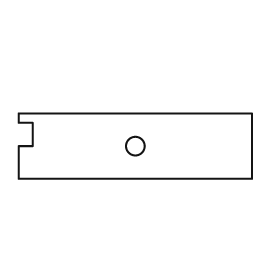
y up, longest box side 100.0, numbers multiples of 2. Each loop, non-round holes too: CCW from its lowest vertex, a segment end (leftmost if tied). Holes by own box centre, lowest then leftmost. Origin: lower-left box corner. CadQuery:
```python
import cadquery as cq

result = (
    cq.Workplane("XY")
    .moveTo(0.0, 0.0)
    .lineTo(100.0, 0.0)
    .lineTo(100.0, 28.0)
    .lineTo(0.0, 28.0)
    .lineTo(0.0, 24.0)
    .lineTo(6.0, 24.0)
    .lineTo(6.0, 14.0)
    .lineTo(0.0, 14.0)
    .close()
    .moveTo(50.0, 14.0)
    .circle(4.0)
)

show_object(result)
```